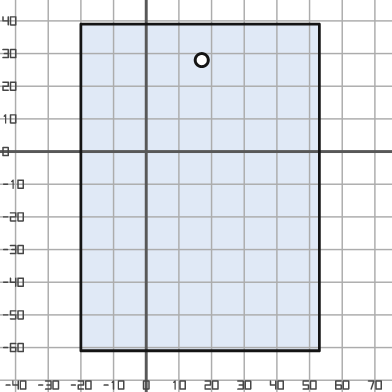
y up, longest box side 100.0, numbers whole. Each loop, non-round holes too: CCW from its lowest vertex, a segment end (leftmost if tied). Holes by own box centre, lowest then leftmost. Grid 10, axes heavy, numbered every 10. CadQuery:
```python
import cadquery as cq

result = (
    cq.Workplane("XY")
    .moveTo(-20.0, -61.0)
    .lineTo(53.0, -61.0)
    .lineTo(53.0, 39.0)
    .lineTo(-20.0, 39.0)
    .close()
    .moveTo(17.0, 28.0)
    .circle(2.0)
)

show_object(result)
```